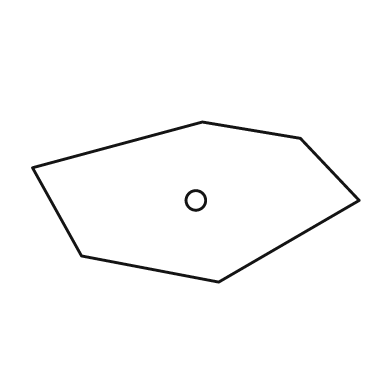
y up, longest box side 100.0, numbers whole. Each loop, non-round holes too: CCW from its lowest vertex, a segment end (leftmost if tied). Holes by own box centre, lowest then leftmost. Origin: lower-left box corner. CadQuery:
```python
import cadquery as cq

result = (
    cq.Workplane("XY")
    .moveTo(57.0, 0.0)
    .lineTo(100.0, 25.0)
    .lineTo(82.0, 44.0)
    .lineTo(52.0, 49.0)
    .lineTo(0.0, 35.0)
    .lineTo(15.0, 8.0)
    .close()
    .moveTo(50.0, 25.0)
    .circle(3.0)
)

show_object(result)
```